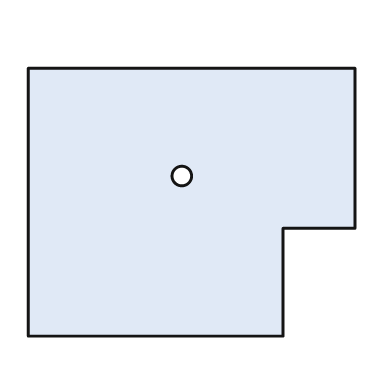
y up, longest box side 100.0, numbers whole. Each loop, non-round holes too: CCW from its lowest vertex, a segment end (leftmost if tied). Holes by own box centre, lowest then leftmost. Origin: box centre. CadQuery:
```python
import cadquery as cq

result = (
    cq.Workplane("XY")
    .moveTo(-50.0, -41.0)
    .lineTo(28.0, -41.0)
    .lineTo(28.0, -8.0)
    .lineTo(50.0, -8.0)
    .lineTo(50.0, 41.0)
    .lineTo(-50.0, 41.0)
    .close()
    .moveTo(-3.0, 8.0)
    .circle(3.0)
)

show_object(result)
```